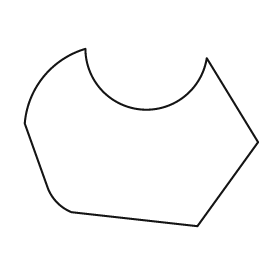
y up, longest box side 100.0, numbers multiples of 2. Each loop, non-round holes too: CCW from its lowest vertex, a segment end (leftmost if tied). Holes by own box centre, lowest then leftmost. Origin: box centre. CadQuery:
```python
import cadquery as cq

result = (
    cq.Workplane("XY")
    .moveTo(24.0, -38.0)
    .lineTo(50.0, -2.0)
    .lineTo(28.0, 34.0)
    .threePointArc((0.0, 12.0), (-24.0, 38.0))
    .threePointArc((-42.0, 26.0), (-50.0, 6.0))
    .lineTo(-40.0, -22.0)
    .threePointArc((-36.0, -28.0), (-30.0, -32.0))
    .close()
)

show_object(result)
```